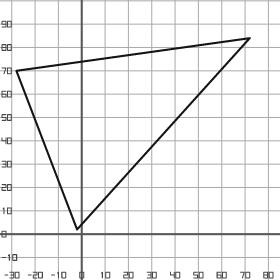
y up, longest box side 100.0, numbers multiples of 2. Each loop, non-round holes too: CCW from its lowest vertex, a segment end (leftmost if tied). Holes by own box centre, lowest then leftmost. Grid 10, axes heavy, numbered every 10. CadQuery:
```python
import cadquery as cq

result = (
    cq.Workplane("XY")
    .moveTo(-2.0, 2.0)
    .lineTo(72.0, 84.0)
    .lineTo(-28.0, 70.0)
    .close()
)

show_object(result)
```